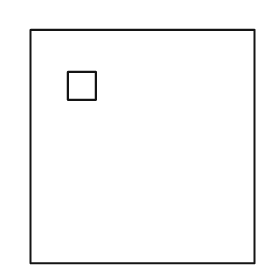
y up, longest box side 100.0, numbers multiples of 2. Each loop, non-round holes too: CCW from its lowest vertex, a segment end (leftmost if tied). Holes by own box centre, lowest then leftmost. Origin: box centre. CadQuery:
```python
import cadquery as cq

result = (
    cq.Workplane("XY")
    .moveTo(-48.0, -50.0)
    .lineTo(48.0, -50.0)
    .lineTo(48.0, 50.0)
    .lineTo(-48.0, 50.0)
    .close()
    .moveTo(-32.0, 20.0)
    .lineTo(-20.0, 20.0)
    .lineTo(-20.0, 32.0)
    .lineTo(-32.0, 32.0)
    .close()
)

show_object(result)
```